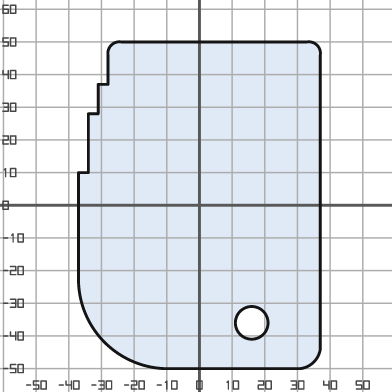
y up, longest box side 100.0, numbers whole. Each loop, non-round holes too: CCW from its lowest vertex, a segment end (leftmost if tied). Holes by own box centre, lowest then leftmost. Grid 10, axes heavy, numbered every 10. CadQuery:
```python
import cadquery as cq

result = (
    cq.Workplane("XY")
    .moveTo(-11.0, -50.0)
    .lineTo(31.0, -50.0)
    .threePointArc((35.0, -48.0), (37.0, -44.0))
    .lineTo(37.0, 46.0)
    .threePointArc((36.0, 49.0), (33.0, 50.0))
    .lineTo(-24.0, 50.0)
    .threePointArc((-27.0, 49.0), (-28.0, 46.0))
    .lineTo(-28.0, 37.0)
    .lineTo(-31.0, 37.0)
    .lineTo(-31.0, 28.0)
    .lineTo(-34.0, 28.0)
    .lineTo(-34.0, 10.0)
    .lineTo(-37.0, 10.0)
    .lineTo(-37.0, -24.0)
    .threePointArc((-29.0, -42.0), (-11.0, -50.0))
    .close()
    .moveTo(16.0, -36.0)
    .circle(5.0)
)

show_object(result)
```